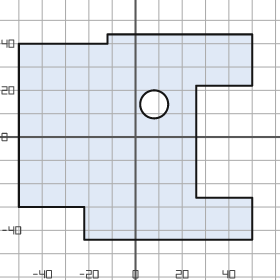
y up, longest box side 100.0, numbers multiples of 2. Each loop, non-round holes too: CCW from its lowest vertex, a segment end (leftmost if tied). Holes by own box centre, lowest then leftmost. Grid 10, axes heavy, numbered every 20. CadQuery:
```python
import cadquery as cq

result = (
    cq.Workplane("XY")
    .moveTo(-22.0, -44.0)
    .lineTo(50.0, -44.0)
    .lineTo(50.0, -26.0)
    .lineTo(26.0, -26.0)
    .lineTo(26.0, 22.0)
    .lineTo(50.0, 22.0)
    .lineTo(50.0, 44.0)
    .lineTo(-12.0, 44.0)
    .lineTo(-12.0, 40.0)
    .lineTo(-50.0, 40.0)
    .lineTo(-50.0, -30.0)
    .lineTo(-22.0, -30.0)
    .close()
    .moveTo(8.0, 14.0)
    .circle(6.0)
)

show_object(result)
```